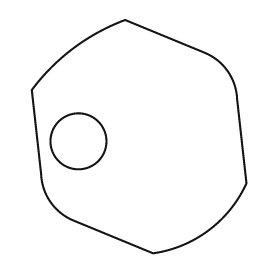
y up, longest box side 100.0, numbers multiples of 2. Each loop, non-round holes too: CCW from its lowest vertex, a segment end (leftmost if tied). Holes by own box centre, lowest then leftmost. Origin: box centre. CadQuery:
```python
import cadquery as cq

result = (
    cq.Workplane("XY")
    .moveTo(6.0, -50.0)
    .threePointArc((30.0, -40.0), (46.0, -20.0))
    .lineTo(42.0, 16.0)
    .threePointArc((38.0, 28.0), (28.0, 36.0))
    .lineTo(-6.0, 50.0)
    .threePointArc((-28.0, 38.0), (-46.0, 20.0))
    .lineTo(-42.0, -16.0)
    .threePointArc((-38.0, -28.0), (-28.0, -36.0))
    .close()
    .moveTo(-26.0, -2.0)
    .circle(12.0)
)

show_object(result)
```